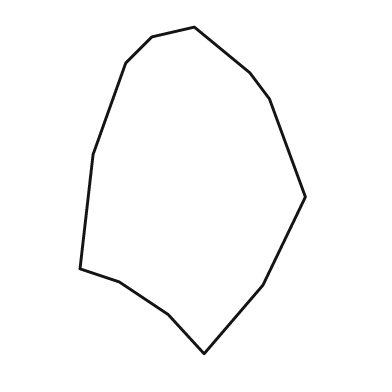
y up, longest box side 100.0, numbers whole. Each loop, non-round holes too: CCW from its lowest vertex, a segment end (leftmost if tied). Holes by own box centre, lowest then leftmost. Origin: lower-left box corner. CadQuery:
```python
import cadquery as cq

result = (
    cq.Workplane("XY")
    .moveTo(38.0, 0.0)
    .lineTo(56.0, 21.0)
    .lineTo(69.0, 48.0)
    .lineTo(58.0, 78.0)
    .lineTo(52.0, 86.0)
    .lineTo(35.0, 100.0)
    .lineTo(22.0, 97.0)
    .lineTo(14.0, 89.0)
    .lineTo(4.0, 61.0)
    .lineTo(0.0, 26.0)
    .lineTo(12.0, 22.0)
    .lineTo(27.0, 12.0)
    .close()
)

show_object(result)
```